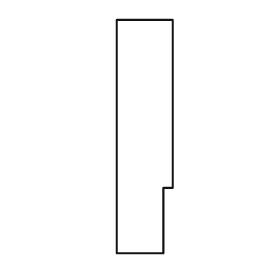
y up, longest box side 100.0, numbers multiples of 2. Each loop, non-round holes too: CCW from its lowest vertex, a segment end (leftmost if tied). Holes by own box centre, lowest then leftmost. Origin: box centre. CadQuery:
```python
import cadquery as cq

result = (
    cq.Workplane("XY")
    .moveTo(-12.0, -50.0)
    .lineTo(8.0, -50.0)
    .lineTo(8.0, -22.0)
    .lineTo(12.0, -22.0)
    .lineTo(12.0, 50.0)
    .lineTo(-12.0, 50.0)
    .close()
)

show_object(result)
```